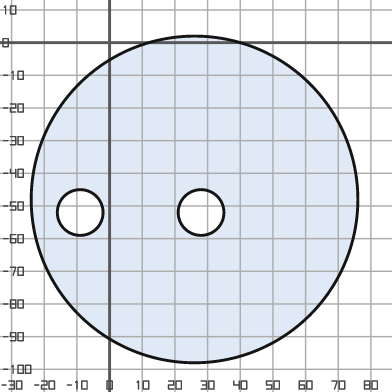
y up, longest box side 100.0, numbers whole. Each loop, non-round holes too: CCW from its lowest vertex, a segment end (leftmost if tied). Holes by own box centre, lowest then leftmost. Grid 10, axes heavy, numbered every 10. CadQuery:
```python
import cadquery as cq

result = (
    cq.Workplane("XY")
    .moveTo(26.0, -48.0)
    .circle(50.0)
    .moveTo(-9.0, -52.0)
    .circle(7.0)
    .moveTo(28.0, -52.0)
    .circle(7.0)
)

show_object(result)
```